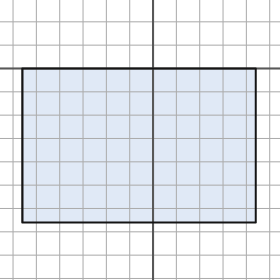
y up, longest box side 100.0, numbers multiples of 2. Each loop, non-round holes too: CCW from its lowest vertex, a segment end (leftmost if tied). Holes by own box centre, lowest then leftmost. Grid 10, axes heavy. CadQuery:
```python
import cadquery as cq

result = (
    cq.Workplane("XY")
    .moveTo(-56.0, -66.0)
    .lineTo(44.0, -66.0)
    .lineTo(44.0, 0.0)
    .lineTo(-56.0, 0.0)
    .close()
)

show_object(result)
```